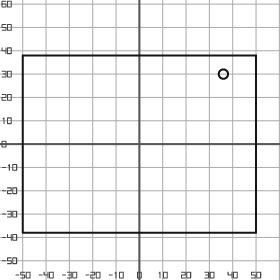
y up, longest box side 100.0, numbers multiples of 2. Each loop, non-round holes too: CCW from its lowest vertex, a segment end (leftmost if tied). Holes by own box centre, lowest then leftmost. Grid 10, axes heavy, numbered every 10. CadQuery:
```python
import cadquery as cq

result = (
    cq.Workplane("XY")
    .moveTo(-50.0, -38.0)
    .lineTo(50.0, -38.0)
    .lineTo(50.0, 38.0)
    .lineTo(-50.0, 38.0)
    .close()
    .moveTo(36.0, 30.0)
    .circle(2.0)
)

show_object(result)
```